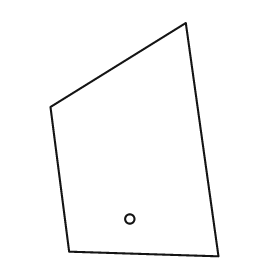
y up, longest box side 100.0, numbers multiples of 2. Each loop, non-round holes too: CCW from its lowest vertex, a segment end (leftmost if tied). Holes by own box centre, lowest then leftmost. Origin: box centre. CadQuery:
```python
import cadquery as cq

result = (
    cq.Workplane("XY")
    .moveTo(36.0, -50.0)
    .lineTo(22.0, 50.0)
    .lineTo(-36.0, 14.0)
    .lineTo(-28.0, -48.0)
    .close()
    .moveTo(-2.0, -34.0)
    .circle(2.0)
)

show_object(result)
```